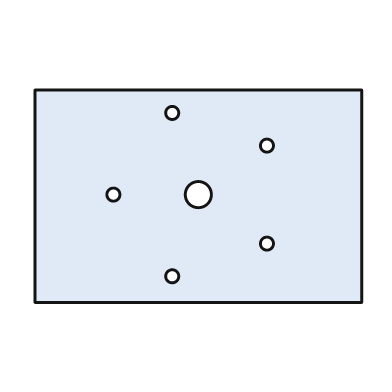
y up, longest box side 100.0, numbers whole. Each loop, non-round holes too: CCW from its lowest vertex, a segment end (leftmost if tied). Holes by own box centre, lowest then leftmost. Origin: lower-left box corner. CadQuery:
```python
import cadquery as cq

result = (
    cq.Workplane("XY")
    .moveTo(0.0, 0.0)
    .lineTo(100.0, 0.0)
    .lineTo(100.0, 65.0)
    .lineTo(0.0, 65.0)
    .close()
    .moveTo(42.0, 8.0)
    .circle(2.0)
    .moveTo(71.0, 18.0)
    .circle(2.0)
    .moveTo(24.0, 33.0)
    .circle(2.0)
    .moveTo(50.0, 33.0)
    .circle(4.0)
    .moveTo(71.0, 48.0)
    .circle(2.0)
    .moveTo(42.0, 58.0)
    .circle(2.0)
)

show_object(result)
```